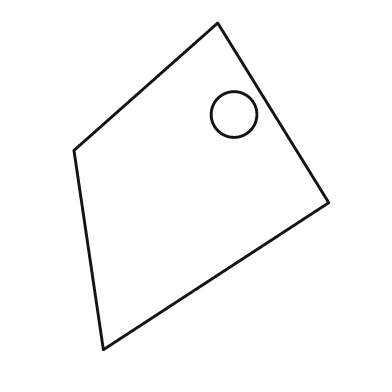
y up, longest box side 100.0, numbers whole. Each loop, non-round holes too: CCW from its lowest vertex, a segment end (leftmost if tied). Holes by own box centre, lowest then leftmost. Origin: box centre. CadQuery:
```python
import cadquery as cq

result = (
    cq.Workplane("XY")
    .moveTo(-30.0, -50.0)
    .lineTo(39.0, -5.0)
    .lineTo(5.0, 50.0)
    .lineTo(-39.0, 11.0)
    .close()
    .moveTo(10.0, 22.0)
    .circle(7.0)
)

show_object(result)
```